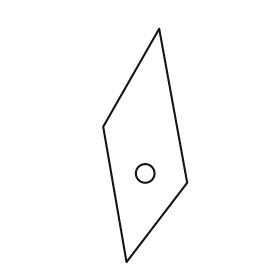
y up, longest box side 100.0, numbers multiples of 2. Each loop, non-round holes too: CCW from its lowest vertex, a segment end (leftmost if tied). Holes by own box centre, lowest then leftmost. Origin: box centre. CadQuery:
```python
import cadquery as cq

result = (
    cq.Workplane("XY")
    .moveTo(-8.0, -50.0)
    .lineTo(18.0, -16.0)
    .lineTo(6.0, 50.0)
    .lineTo(-18.0, 8.0)
    .close()
    .moveTo(0.0, -12.0)
    .circle(4.0)
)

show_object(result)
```